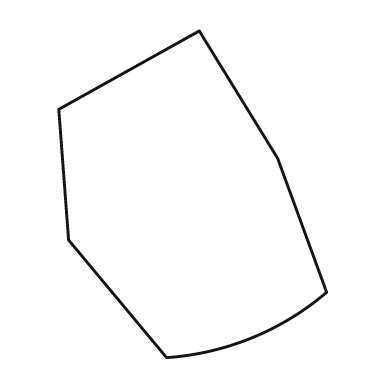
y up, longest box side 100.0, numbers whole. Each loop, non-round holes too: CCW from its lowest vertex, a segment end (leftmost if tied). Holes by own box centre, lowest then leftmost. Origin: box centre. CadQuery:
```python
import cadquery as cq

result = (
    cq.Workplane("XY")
    .moveTo(-8.0, -50.0)
    .threePointArc((18.0, -44.0), (41.0, -30.0))
    .lineTo(26.0, 11.0)
    .lineTo(2.0, 50.0)
    .lineTo(-41.0, 26.0)
    .lineTo(-38.0, -14.0)
    .close()
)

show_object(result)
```